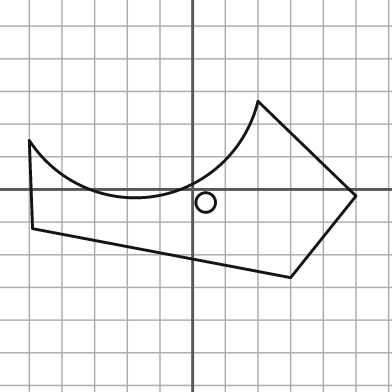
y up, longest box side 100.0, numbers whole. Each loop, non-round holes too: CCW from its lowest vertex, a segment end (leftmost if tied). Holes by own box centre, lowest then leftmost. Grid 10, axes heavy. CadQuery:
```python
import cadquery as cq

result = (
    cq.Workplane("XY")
    .moveTo(30.0, -27.0)
    .lineTo(50.0, -2.0)
    .lineTo(20.0, 27.0)
    .threePointArc((-11.0, -2.0), (-50.0, 15.0))
    .lineTo(-49.0, -12.0)
    .close()
    .moveTo(4.0, -4.0)
    .circle(3.0)
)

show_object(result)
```